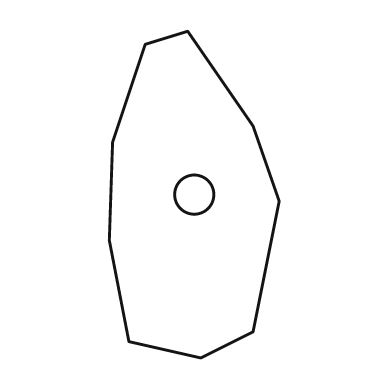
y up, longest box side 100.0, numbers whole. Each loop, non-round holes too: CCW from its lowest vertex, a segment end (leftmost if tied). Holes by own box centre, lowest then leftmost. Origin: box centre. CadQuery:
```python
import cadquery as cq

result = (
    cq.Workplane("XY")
    .moveTo(2.0, -50.0)
    .lineTo(18.0, -42.0)
    .lineTo(26.0, -2.0)
    .lineTo(18.0, 21.0)
    .lineTo(-2.0, 50.0)
    .lineTo(-15.0, 46.0)
    .lineTo(-25.0, 16.0)
    .lineTo(-26.0, -14.0)
    .lineTo(-20.0, -45.0)
    .close()
    .moveTo(0.0, 0.0)
    .circle(6.0)
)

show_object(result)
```